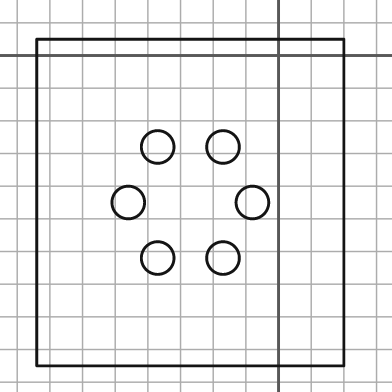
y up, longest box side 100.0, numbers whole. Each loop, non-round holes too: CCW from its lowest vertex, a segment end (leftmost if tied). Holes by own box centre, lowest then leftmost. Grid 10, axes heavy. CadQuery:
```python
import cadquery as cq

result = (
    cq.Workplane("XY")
    .moveTo(-74.0, -95.0)
    .lineTo(20.0, -95.0)
    .lineTo(20.0, 5.0)
    .lineTo(-74.0, 5.0)
    .close()
    .moveTo(-37.0, -62.0)
    .circle(5.0)
    .moveTo(-17.0, -62.0)
    .circle(5.0)
    .moveTo(-46.0, -45.0)
    .circle(5.0)
    .moveTo(-8.0, -45.0)
    .circle(5.0)
    .moveTo(-37.0, -28.0)
    .circle(5.0)
    .moveTo(-17.0, -28.0)
    .circle(5.0)
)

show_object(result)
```